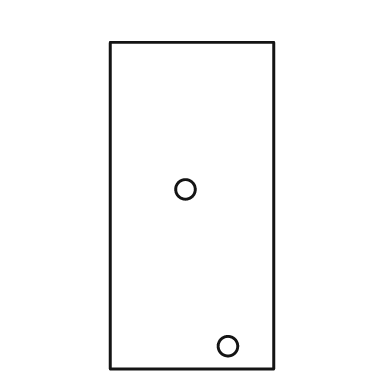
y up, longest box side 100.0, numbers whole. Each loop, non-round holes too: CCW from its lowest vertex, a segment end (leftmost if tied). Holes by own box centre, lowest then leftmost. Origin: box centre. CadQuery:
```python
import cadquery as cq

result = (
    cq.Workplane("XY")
    .moveTo(-25.0, -50.0)
    .lineTo(25.0, -50.0)
    .lineTo(25.0, 50.0)
    .lineTo(-25.0, 50.0)
    .close()
    .moveTo(11.0, -43.0)
    .circle(3.0)
    .moveTo(-2.0, 5.0)
    .circle(3.0)
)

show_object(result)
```